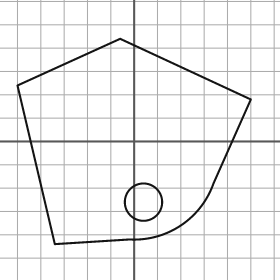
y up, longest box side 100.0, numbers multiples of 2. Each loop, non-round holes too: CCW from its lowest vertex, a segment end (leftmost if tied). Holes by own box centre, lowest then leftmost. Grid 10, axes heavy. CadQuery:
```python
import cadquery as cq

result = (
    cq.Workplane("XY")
    .moveTo(-34.0, -44.0)
    .lineTo(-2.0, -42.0)
    .threePointArc((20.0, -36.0), (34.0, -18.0))
    .lineTo(50.0, 18.0)
    .lineTo(-6.0, 44.0)
    .lineTo(-50.0, 24.0)
    .close()
    .moveTo(4.0, -26.0)
    .circle(8.0)
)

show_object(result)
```